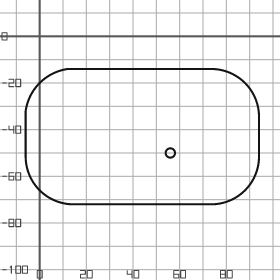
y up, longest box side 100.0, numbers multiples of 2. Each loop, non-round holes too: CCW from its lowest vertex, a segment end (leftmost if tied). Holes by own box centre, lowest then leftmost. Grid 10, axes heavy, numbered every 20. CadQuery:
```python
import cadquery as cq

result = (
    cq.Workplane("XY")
    .moveTo(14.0, -72.0)
    .lineTo(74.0, -72.0)
    .threePointArc((88.0, -66.0), (94.0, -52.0))
    .lineTo(94.0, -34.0)
    .threePointArc((88.0, -20.0), (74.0, -14.0))
    .lineTo(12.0, -14.0)
    .threePointArc((0.0, -20.0), (-6.0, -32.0))
    .lineTo(-6.0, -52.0)
    .threePointArc((0.0, -66.0), (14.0, -72.0))
    .close()
    .moveTo(56.0, -50.0)
    .circle(2.0)
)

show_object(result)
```